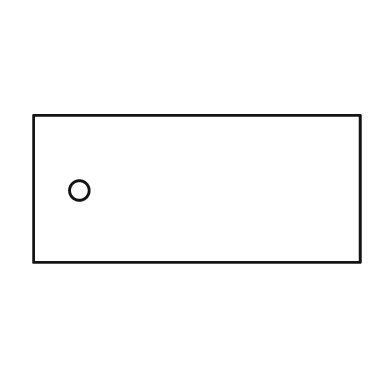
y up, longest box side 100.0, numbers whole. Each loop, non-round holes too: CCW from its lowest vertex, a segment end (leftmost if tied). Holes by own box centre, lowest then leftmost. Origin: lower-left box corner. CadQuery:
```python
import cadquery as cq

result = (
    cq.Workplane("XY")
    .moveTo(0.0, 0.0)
    .lineTo(100.0, 0.0)
    .lineTo(100.0, 45.0)
    .lineTo(0.0, 45.0)
    .close()
    .moveTo(14.0, 22.0)
    .circle(3.0)
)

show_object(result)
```